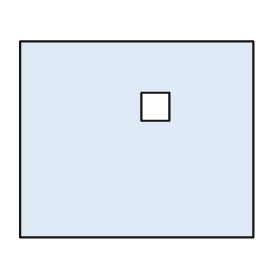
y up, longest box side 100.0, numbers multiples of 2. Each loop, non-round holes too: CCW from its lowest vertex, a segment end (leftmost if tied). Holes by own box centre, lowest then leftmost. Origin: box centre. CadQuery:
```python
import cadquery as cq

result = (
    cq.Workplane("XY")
    .moveTo(-50.0, -42.0)
    .lineTo(50.0, -42.0)
    .lineTo(50.0, 42.0)
    .lineTo(-50.0, 42.0)
    .close()
    .moveTo(2.0, 8.0)
    .lineTo(14.0, 8.0)
    .lineTo(14.0, 20.0)
    .lineTo(2.0, 20.0)
    .close()
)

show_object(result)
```